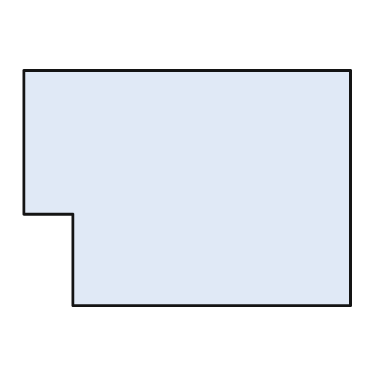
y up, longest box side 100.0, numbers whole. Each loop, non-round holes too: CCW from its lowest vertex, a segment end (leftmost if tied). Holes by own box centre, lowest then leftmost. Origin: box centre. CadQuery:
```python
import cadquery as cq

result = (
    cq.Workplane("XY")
    .moveTo(-35.0, -36.0)
    .lineTo(50.0, -36.0)
    .lineTo(50.0, 36.0)
    .lineTo(-50.0, 36.0)
    .lineTo(-50.0, -8.0)
    .lineTo(-35.0, -8.0)
    .close()
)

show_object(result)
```